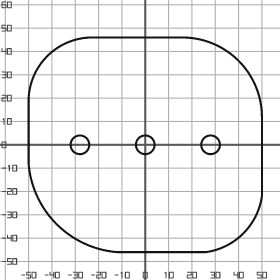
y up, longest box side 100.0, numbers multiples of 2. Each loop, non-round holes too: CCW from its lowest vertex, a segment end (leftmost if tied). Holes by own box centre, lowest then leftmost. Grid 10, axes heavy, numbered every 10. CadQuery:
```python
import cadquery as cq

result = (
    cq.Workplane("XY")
    .moveTo(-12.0, -46.0)
    .lineTo(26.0, -46.0)
    .threePointArc((42.0, -38.0), (50.0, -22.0))
    .lineTo(50.0, 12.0)
    .threePointArc((40.0, 36.0), (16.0, 46.0))
    .lineTo(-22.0, 46.0)
    .threePointArc((-42.0, 38.0), (-50.0, 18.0))
    .lineTo(-50.0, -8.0)
    .threePointArc((-38.0, -34.0), (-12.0, -46.0))
    .close()
    .moveTo(-28.0, 0.0)
    .circle(4.0)
    .moveTo(0.0, 0.0)
    .circle(4.0)
    .moveTo(28.0, 0.0)
    .circle(4.0)
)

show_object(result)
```